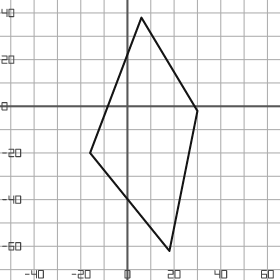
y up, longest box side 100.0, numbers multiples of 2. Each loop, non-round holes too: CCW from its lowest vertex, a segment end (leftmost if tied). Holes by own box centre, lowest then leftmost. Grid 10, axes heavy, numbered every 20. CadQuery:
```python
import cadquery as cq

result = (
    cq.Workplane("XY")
    .moveTo(18.0, -62.0)
    .lineTo(30.0, -2.0)
    .lineTo(6.0, 38.0)
    .lineTo(-16.0, -20.0)
    .close()
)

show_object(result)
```